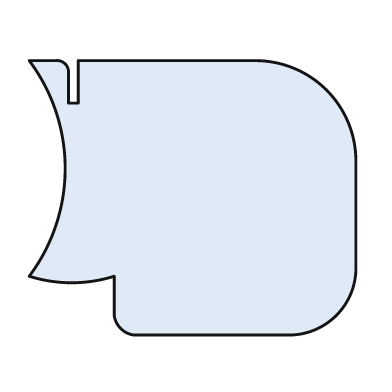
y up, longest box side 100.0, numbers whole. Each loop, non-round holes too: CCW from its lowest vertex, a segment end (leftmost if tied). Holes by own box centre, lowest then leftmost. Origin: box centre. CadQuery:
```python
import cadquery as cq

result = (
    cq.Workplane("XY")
    .moveTo(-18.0, -42.0)
    .lineTo(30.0, -42.0)
    .threePointArc((44.0, -36.0), (50.0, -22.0))
    .lineTo(50.0, 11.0)
    .threePointArc((41.0, 33.0), (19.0, 42.0))
    .lineTo(-35.0, 42.0)
    .lineTo(-35.0, 29.0)
    .lineTo(-38.0, 29.0)
    .lineTo(-38.0, 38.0)
    .threePointArc((-39.0, 41.0), (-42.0, 42.0))
    .lineTo(-50.0, 42.0)
    .threePointArc((-39.0, 9.0), (-50.0, -24.0))
    .threePointArc((-37.0, -26.0), (-24.0, -24.0))
    .lineTo(-24.0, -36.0)
    .threePointArc((-22.0, -40.0), (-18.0, -42.0))
    .close()
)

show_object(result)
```